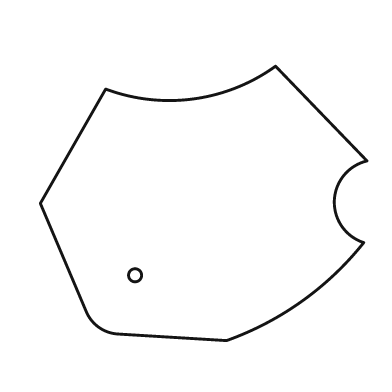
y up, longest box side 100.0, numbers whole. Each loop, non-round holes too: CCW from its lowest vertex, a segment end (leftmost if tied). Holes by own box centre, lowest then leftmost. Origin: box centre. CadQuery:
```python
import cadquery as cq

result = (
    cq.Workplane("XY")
    .moveTo(7.0, -42.0)
    .threePointArc((30.0, -30.0), (49.0, -12.0))
    .threePointArc((40.0, 1.0), (50.0, 13.0))
    .lineTo(22.0, 42.0)
    .threePointArc((-3.0, 32.0), (-30.0, 35.0))
    .lineTo(-50.0, 0.0)
    .lineTo(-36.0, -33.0)
    .threePointArc((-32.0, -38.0), (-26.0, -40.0))
    .close()
    .moveTo(-21.0, -22.0)
    .circle(2.0)
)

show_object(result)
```